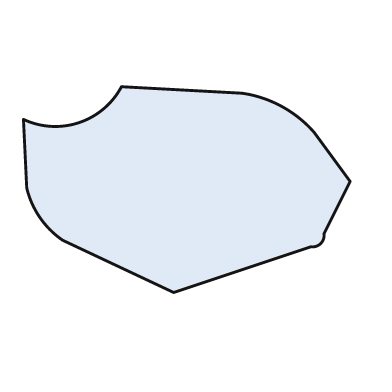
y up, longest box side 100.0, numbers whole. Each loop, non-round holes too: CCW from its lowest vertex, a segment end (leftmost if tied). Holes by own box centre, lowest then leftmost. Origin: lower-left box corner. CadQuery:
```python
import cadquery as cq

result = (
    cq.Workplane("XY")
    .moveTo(46.0, 0.0)
    .lineTo(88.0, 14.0)
    .threePointArc((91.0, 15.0), (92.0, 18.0))
    .lineTo(100.0, 34.0)
    .lineTo(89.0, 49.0)
    .threePointArc((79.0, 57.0), (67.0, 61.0))
    .lineTo(30.0, 63.0)
    .threePointArc((17.0, 52.0), (0.0, 53.0))
    .lineTo(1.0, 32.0)
    .threePointArc((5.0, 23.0), (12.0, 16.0))
    .close()
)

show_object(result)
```